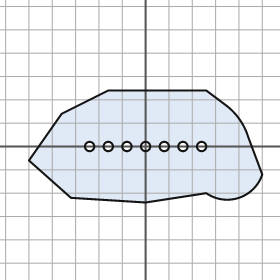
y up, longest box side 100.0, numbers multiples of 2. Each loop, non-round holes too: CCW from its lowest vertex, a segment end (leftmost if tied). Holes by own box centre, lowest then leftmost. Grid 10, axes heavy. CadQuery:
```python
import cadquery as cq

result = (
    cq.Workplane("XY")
    .moveTo(0.0, -24.0)
    .lineTo(26.0, -20.0)
    .threePointArc((40.0, -22.0), (50.0, -12.0))
    .lineTo(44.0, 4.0)
    .threePointArc((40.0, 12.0), (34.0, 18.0))
    .lineTo(26.0, 24.0)
    .lineTo(-16.0, 24.0)
    .lineTo(-36.0, 14.0)
    .lineTo(-50.0, -6.0)
    .lineTo(-32.0, -22.0)
    .close()
    .moveTo(-24.0, 0.0)
    .circle(2.0)
    .moveTo(-16.0, 0.0)
    .circle(2.0)
    .moveTo(-8.0, 0.0)
    .circle(2.0)
    .moveTo(0.0, 0.0)
    .circle(2.0)
    .moveTo(8.0, 0.0)
    .circle(2.0)
    .moveTo(16.0, 0.0)
    .circle(2.0)
    .moveTo(24.0, 0.0)
    .circle(2.0)
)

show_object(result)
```